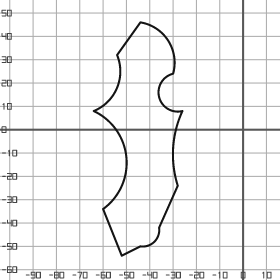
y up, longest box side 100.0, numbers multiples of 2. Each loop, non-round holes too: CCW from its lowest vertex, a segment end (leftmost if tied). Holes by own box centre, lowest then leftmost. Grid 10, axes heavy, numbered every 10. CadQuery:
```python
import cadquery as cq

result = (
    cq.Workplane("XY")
    .moveTo(-52.0, -54.0)
    .lineTo(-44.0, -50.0)
    .threePointArc((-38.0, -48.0), (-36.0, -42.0))
    .lineTo(-28.0, -24.0)
    .threePointArc((-30.0, -8.0), (-26.0, 8.0))
    .threePointArc((-36.0, 14.0), (-30.0, 24.0))
    .threePointArc((-32.0, 38.0), (-44.0, 46.0))
    .lineTo(-54.0, 32.0)
    .threePointArc((-54.0, 18.0), (-64.0, 8.0))
    .threePointArc((-50.0, -12.0), (-60.0, -34.0))
    .close()
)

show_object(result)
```